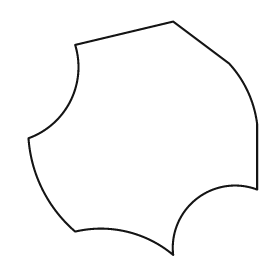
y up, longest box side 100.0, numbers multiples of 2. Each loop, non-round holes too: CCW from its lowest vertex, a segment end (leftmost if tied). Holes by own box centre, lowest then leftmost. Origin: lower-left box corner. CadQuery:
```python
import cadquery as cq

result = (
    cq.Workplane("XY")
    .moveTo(62.0, 0.0)
    .threePointArc((72.0, 24.0), (98.0, 28.0))
    .lineTo(98.0, 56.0)
    .threePointArc((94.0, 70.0), (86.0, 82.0))
    .lineTo(62.0, 100.0)
    .lineTo(20.0, 90.0)
    .threePointArc((18.0, 66.0), (0.0, 50.0))
    .threePointArc((6.0, 28.0), (20.0, 10.0))
    .threePointArc((42.0, 10.0), (62.0, 0.0))
    .close()
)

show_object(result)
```